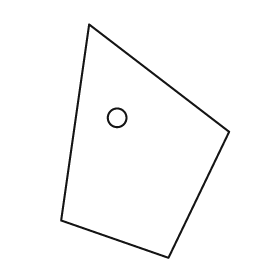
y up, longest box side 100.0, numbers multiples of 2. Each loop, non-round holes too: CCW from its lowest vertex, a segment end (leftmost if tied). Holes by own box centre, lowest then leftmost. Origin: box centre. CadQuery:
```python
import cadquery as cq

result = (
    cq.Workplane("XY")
    .moveTo(10.0, -50.0)
    .lineTo(36.0, 4.0)
    .lineTo(-24.0, 50.0)
    .lineTo(-36.0, -34.0)
    .close()
    .moveTo(-12.0, 10.0)
    .circle(4.0)
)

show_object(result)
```